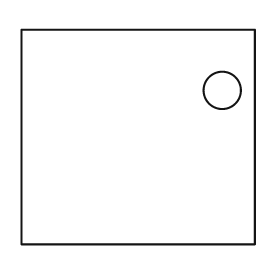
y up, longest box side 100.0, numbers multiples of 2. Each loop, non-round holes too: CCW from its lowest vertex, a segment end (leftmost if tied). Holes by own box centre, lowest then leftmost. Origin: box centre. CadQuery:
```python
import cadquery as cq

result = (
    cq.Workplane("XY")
    .moveTo(-50.0, -46.0)
    .lineTo(50.0, -46.0)
    .lineTo(50.0, 46.0)
    .lineTo(-50.0, 46.0)
    .close()
    .moveTo(36.0, 20.0)
    .circle(8.0)
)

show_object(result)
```